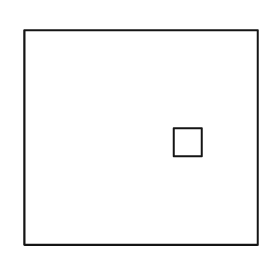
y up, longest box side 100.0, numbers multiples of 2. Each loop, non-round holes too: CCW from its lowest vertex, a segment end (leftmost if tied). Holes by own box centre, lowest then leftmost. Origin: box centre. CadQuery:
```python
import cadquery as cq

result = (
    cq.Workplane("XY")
    .moveTo(-50.0, -46.0)
    .lineTo(50.0, -46.0)
    .lineTo(50.0, 46.0)
    .lineTo(-50.0, 46.0)
    .close()
    .moveTo(14.0, -8.0)
    .lineTo(26.0, -8.0)
    .lineTo(26.0, 4.0)
    .lineTo(14.0, 4.0)
    .close()
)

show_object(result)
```